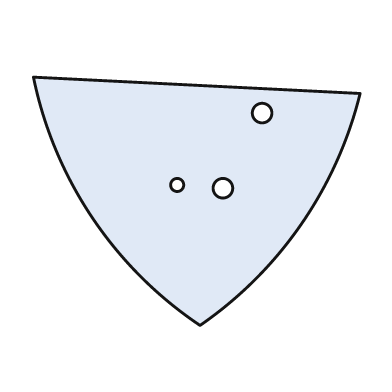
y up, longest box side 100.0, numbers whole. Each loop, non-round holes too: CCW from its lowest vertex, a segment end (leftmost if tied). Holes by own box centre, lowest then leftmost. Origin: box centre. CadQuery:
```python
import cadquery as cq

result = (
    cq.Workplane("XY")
    .moveTo(1.0, -38.0)
    .threePointArc((32.0, -7.0), (50.0, 33.0))
    .lineTo(-50.0, 38.0)
    .threePointArc((-32.0, -5.0), (1.0, -38.0))
    .close()
    .moveTo(8.0, 4.0)
    .circle(3.0)
    .moveTo(-6.0, 5.0)
    .circle(2.0)
    .moveTo(20.0, 27.0)
    .circle(3.0)
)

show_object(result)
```